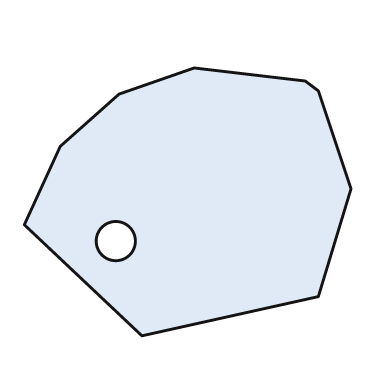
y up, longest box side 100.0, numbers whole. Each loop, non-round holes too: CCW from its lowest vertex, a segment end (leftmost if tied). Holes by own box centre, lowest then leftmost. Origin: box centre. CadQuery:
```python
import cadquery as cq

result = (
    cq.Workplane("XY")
    .moveTo(-14.0, -41.0)
    .lineTo(40.0, -29.0)
    .lineTo(50.0, 4.0)
    .lineTo(40.0, 34.0)
    .lineTo(36.0, 37.0)
    .lineTo(2.0, 41.0)
    .lineTo(-21.0, 33.0)
    .lineTo(-39.0, 17.0)
    .lineTo(-50.0, -7.0)
    .close()
    .moveTo(-22.0, -12.0)
    .circle(6.0)
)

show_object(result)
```